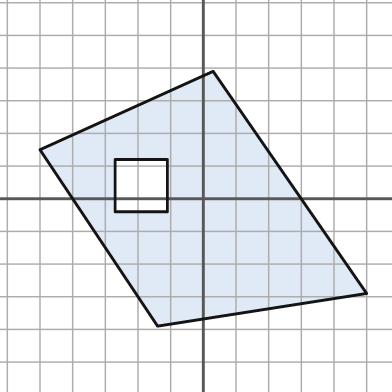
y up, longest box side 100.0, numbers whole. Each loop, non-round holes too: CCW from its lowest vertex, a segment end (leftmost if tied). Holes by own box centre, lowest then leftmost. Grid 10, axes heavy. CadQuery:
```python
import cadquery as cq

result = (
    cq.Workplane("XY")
    .moveTo(-14.0, -39.0)
    .lineTo(50.0, -29.0)
    .lineTo(3.0, 39.0)
    .lineTo(-50.0, 15.0)
    .close()
    .moveTo(-27.0, -4.0)
    .lineTo(-11.0, -4.0)
    .lineTo(-11.0, 12.0)
    .lineTo(-27.0, 12.0)
    .close()
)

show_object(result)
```